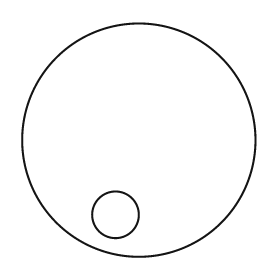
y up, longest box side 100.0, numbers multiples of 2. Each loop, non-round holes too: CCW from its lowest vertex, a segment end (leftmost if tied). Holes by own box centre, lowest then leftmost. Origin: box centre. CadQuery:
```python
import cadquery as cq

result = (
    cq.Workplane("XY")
    .moveTo(0.0, 0.0)
    .circle(50.0)
    .moveTo(-10.0, -32.0)
    .circle(10.0)
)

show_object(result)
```